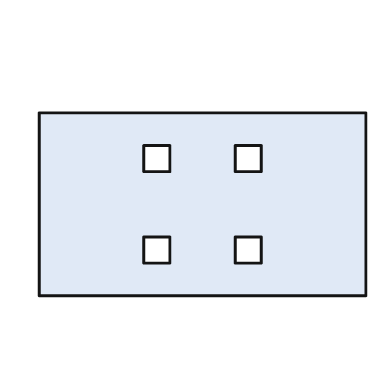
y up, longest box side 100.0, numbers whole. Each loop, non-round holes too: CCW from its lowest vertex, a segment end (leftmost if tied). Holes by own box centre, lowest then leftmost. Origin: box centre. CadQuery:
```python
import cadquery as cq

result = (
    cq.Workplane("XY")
    .moveTo(-50.0, -28.0)
    .lineTo(50.0, -28.0)
    .lineTo(50.0, 28.0)
    .lineTo(-50.0, 28.0)
    .close()
    .moveTo(-18.0, -18.0)
    .lineTo(-10.0, -18.0)
    .lineTo(-10.0, -10.0)
    .lineTo(-18.0, -10.0)
    .close()
    .moveTo(10.0, -18.0)
    .lineTo(18.0, -18.0)
    .lineTo(18.0, -10.0)
    .lineTo(10.0, -10.0)
    .close()
    .moveTo(-18.0, 10.0)
    .lineTo(-10.0, 10.0)
    .lineTo(-10.0, 18.0)
    .lineTo(-18.0, 18.0)
    .close()
    .moveTo(10.0, 10.0)
    .lineTo(18.0, 10.0)
    .lineTo(18.0, 18.0)
    .lineTo(10.0, 18.0)
    .close()
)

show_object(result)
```